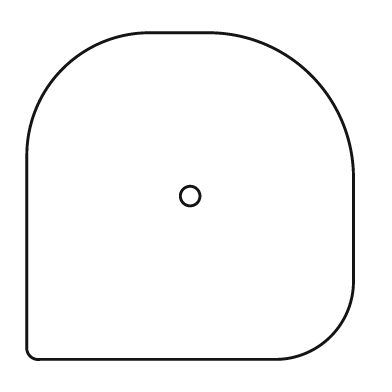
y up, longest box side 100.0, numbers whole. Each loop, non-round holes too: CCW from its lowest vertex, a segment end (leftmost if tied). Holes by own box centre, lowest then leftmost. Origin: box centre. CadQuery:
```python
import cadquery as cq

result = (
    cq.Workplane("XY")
    .moveTo(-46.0, -50.0)
    .lineTo(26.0, -50.0)
    .threePointArc((43.0, -43.0), (50.0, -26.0))
    .lineTo(50.0, 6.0)
    .threePointArc((37.0, 37.0), (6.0, 50.0))
    .lineTo(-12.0, 50.0)
    .threePointArc((-39.0, 39.0), (-50.0, 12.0))
    .lineTo(-50.0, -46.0)
    .threePointArc((-49.0, -49.0), (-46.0, -50.0))
    .close()
    .moveTo(0.0, 0.0)
    .circle(3.0)
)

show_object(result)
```